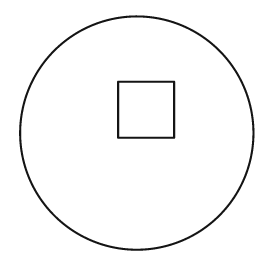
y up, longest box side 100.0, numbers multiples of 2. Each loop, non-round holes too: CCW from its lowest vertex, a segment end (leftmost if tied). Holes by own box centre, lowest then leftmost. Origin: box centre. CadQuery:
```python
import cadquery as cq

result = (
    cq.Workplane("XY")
    .moveTo(0.0, 0.0)
    .circle(50.0)
    .moveTo(-8.0, -2.0)
    .lineTo(16.0, -2.0)
    .lineTo(16.0, 22.0)
    .lineTo(-8.0, 22.0)
    .close()
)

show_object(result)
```